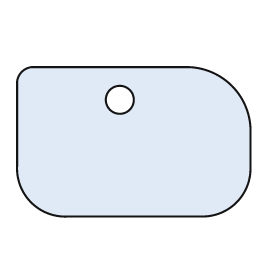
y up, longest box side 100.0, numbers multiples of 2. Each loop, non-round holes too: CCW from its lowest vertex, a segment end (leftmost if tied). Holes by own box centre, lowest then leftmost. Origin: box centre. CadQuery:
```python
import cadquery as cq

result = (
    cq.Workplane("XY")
    .moveTo(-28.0, -32.0)
    .lineTo(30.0, -32.0)
    .threePointArc((44.0, -26.0), (50.0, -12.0))
    .lineTo(50.0, 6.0)
    .threePointArc((42.0, 24.0), (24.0, 32.0))
    .lineTo(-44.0, 32.0)
    .threePointArc((-48.0, 30.0), (-50.0, 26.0))
    .lineTo(-50.0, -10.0)
    .threePointArc((-44.0, -26.0), (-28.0, -32.0))
    .close()
    .moveTo(-6.0, 18.0)
    .circle(6.0)
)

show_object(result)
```